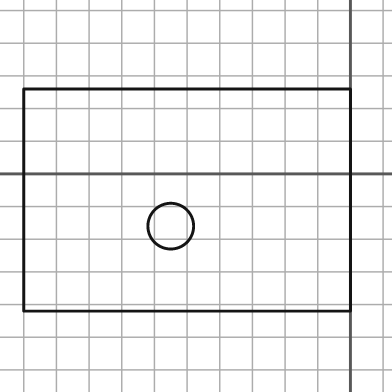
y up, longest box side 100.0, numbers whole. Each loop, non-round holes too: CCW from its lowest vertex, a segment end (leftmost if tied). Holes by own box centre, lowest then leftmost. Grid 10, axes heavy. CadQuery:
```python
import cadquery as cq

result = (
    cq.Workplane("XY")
    .moveTo(-100.0, -42.0)
    .lineTo(0.0, -42.0)
    .lineTo(0.0, 26.0)
    .lineTo(-100.0, 26.0)
    .close()
    .moveTo(-55.0, -16.0)
    .circle(7.0)
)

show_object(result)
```